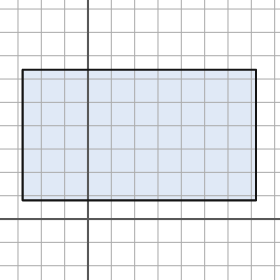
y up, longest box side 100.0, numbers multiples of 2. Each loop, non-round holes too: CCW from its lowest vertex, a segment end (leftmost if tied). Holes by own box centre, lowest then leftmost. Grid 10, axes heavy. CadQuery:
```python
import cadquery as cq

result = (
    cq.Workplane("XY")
    .moveTo(-28.0, 8.0)
    .lineTo(72.0, 8.0)
    .lineTo(72.0, 64.0)
    .lineTo(-28.0, 64.0)
    .close()
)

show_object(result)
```